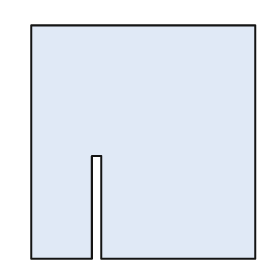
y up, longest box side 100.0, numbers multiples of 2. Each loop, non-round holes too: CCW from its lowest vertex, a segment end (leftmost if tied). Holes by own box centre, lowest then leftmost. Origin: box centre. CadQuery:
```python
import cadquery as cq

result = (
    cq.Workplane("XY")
    .moveTo(-48.0, -50.0)
    .lineTo(-22.0, -50.0)
    .lineTo(-22.0, -6.0)
    .lineTo(-18.0, -6.0)
    .lineTo(-18.0, -50.0)
    .lineTo(48.0, -50.0)
    .lineTo(48.0, 50.0)
    .lineTo(-48.0, 50.0)
    .close()
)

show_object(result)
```